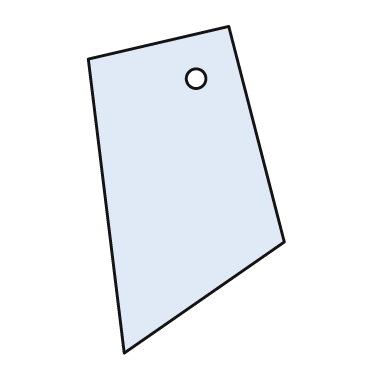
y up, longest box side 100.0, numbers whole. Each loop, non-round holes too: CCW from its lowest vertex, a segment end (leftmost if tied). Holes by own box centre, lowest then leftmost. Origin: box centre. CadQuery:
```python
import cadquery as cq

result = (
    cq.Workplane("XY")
    .moveTo(-19.0, -50.0)
    .lineTo(30.0, -16.0)
    .lineTo(13.0, 50.0)
    .lineTo(-30.0, 40.0)
    .close()
    .moveTo(3.0, 34.0)
    .circle(3.0)
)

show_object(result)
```